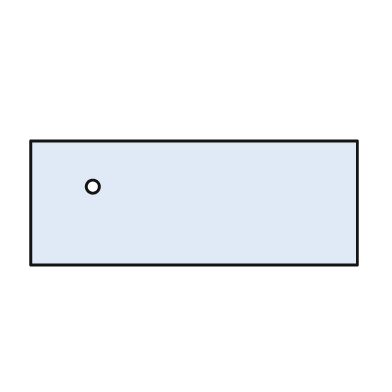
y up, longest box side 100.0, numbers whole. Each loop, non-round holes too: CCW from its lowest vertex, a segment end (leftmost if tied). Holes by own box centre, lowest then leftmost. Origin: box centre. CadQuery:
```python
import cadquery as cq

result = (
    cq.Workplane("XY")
    .moveTo(-50.0, -19.0)
    .lineTo(50.0, -19.0)
    .lineTo(50.0, 19.0)
    .lineTo(-50.0, 19.0)
    .close()
    .moveTo(-31.0, 5.0)
    .circle(2.0)
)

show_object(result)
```